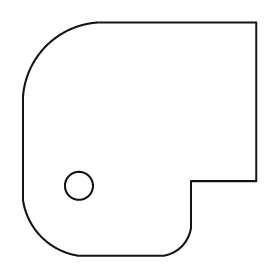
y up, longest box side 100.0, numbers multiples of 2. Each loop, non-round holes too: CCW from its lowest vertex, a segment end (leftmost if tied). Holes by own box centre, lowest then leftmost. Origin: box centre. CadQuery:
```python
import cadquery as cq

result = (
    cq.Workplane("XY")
    .moveTo(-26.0, -50.0)
    .lineTo(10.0, -50.0)
    .threePointArc((18.0, -46.0), (22.0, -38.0))
    .lineTo(22.0, -18.0)
    .lineTo(50.0, -18.0)
    .lineTo(50.0, 50.0)
    .lineTo(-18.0, 50.0)
    .threePointArc((-40.0, 40.0), (-50.0, 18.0))
    .lineTo(-50.0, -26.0)
    .threePointArc((-42.0, -42.0), (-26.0, -50.0))
    .close()
    .moveTo(-26.0, -20.0)
    .circle(6.0)
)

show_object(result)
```